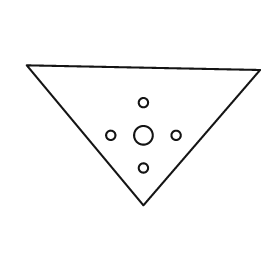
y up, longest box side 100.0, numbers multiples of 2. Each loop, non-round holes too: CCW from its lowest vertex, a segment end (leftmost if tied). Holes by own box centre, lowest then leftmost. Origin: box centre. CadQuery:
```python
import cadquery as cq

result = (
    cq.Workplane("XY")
    .moveTo(0.0, -30.0)
    .lineTo(50.0, 28.0)
    .lineTo(-50.0, 30.0)
    .close()
    .moveTo(0.0, -14.0)
    .circle(2.0)
    .moveTo(-14.0, 0.0)
    .circle(2.0)
    .moveTo(0.0, 0.0)
    .circle(4.0)
    .moveTo(14.0, 0.0)
    .circle(2.0)
    .moveTo(0.0, 14.0)
    .circle(2.0)
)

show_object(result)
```